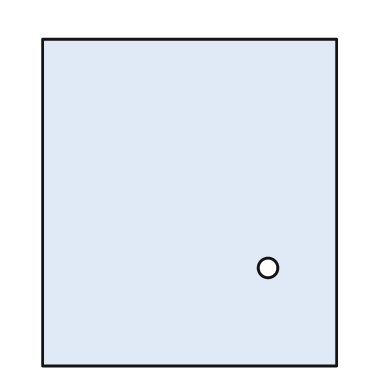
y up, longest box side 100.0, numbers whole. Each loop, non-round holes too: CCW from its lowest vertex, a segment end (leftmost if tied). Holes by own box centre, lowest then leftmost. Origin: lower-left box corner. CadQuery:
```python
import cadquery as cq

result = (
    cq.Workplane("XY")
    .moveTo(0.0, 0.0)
    .lineTo(90.0, 0.0)
    .lineTo(90.0, 100.0)
    .lineTo(0.0, 100.0)
    .close()
    .moveTo(69.0, 30.0)
    .circle(3.0)
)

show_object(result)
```